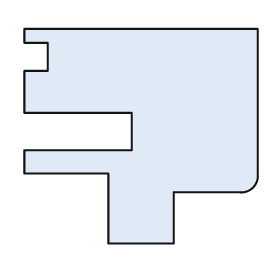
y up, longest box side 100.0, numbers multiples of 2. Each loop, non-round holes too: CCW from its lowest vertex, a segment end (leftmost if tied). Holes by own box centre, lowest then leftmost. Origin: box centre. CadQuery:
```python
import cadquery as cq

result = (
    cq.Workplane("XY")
    .moveTo(-14.0, -46.0)
    .lineTo(14.0, -46.0)
    .lineTo(14.0, -24.0)
    .lineTo(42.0, -24.0)
    .threePointArc((48.0, -22.0), (50.0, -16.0))
    .lineTo(50.0, 46.0)
    .lineTo(-50.0, 46.0)
    .lineTo(-50.0, 40.0)
    .lineTo(-40.0, 40.0)
    .lineTo(-40.0, 28.0)
    .lineTo(-50.0, 28.0)
    .lineTo(-50.0, 10.0)
    .lineTo(-4.0, 10.0)
    .lineTo(-4.0, -6.0)
    .lineTo(-50.0, -6.0)
    .lineTo(-50.0, -16.0)
    .lineTo(-14.0, -16.0)
    .close()
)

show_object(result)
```